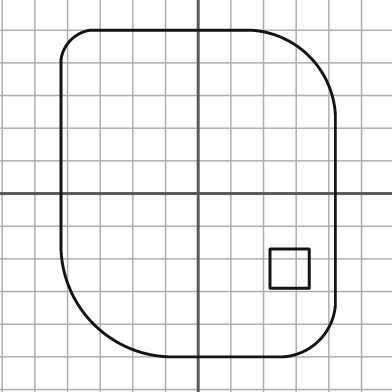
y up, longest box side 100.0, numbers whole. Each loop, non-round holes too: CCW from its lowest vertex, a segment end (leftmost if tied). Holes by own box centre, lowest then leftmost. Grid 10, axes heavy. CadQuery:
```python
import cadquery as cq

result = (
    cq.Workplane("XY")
    .moveTo(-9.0, -50.0)
    .lineTo(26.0, -50.0)
    .threePointArc((37.0, -45.0), (42.0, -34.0))
    .lineTo(42.0, 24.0)
    .threePointArc((34.0, 42.0), (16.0, 50.0))
    .lineTo(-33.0, 50.0)
    .threePointArc((-39.0, 47.0), (-42.0, 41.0))
    .lineTo(-42.0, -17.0)
    .threePointArc((-32.0, -40.0), (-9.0, -50.0))
    .close()
    .moveTo(22.0, -29.0)
    .lineTo(34.0, -29.0)
    .lineTo(34.0, -17.0)
    .lineTo(22.0, -17.0)
    .close()
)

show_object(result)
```